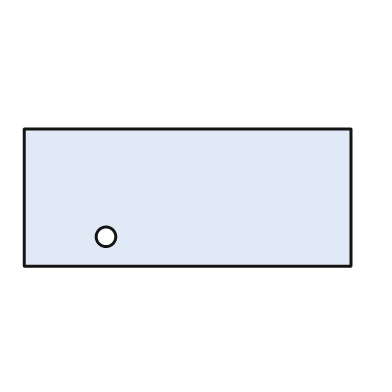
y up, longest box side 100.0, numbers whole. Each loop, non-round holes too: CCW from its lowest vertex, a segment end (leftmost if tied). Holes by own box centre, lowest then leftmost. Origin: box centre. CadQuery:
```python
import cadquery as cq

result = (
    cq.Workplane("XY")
    .moveTo(-50.0, -21.0)
    .lineTo(50.0, -21.0)
    .lineTo(50.0, 21.0)
    .lineTo(-50.0, 21.0)
    .close()
    .moveTo(-25.0, -12.0)
    .circle(3.0)
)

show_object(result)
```